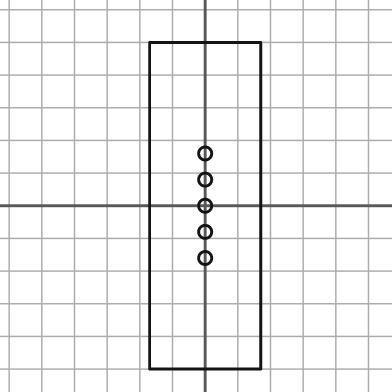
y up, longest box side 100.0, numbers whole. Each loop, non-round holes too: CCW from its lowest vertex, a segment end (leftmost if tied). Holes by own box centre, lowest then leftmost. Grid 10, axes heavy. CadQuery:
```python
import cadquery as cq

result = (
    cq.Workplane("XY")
    .moveTo(-17.0, -50.0)
    .lineTo(17.0, -50.0)
    .lineTo(17.0, 50.0)
    .lineTo(-17.0, 50.0)
    .close()
    .moveTo(0.0, -16.0)
    .circle(2.0)
    .moveTo(0.0, -8.0)
    .circle(2.0)
    .moveTo(0.0, 0.0)
    .circle(2.0)
    .moveTo(0.0, 8.0)
    .circle(2.0)
    .moveTo(0.0, 16.0)
    .circle(2.0)
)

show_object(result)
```